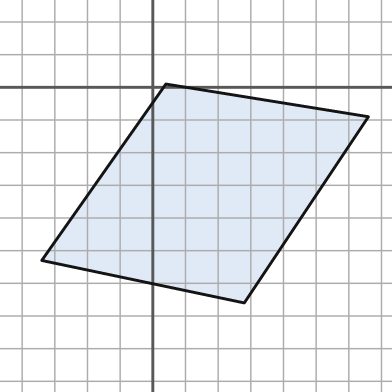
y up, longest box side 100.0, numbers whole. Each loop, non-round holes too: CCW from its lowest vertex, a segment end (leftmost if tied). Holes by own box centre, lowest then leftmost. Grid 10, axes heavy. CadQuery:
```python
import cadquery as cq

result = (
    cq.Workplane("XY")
    .moveTo(28.0, -66.0)
    .lineTo(66.0, -9.0)
    .lineTo(4.0, 1.0)
    .lineTo(-34.0, -53.0)
    .close()
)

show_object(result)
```